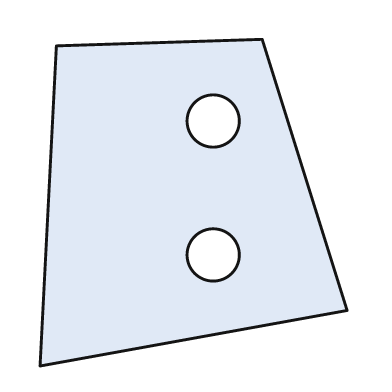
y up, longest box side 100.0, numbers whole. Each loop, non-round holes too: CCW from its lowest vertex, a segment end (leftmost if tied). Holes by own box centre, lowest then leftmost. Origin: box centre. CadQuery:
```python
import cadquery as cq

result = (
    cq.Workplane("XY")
    .moveTo(-47.0, -50.0)
    .lineTo(47.0, -33.0)
    .lineTo(21.0, 50.0)
    .lineTo(-42.0, 48.0)
    .close()
    .moveTo(6.0, -16.0)
    .circle(8.0)
    .moveTo(6.0, 25.0)
    .circle(8.0)
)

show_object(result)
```